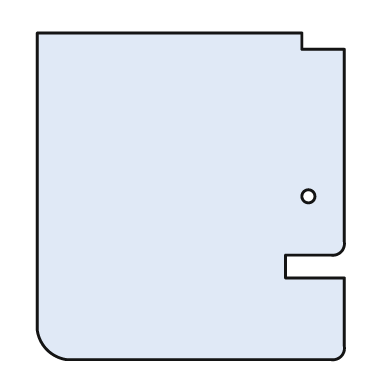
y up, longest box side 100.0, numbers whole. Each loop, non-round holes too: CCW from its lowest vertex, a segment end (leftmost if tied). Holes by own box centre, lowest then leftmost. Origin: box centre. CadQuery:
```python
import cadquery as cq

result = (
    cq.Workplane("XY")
    .moveTo(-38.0, -50.0)
    .lineTo(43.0, -50.0)
    .threePointArc((46.0, -49.0), (47.0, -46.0))
    .lineTo(47.0, -25.0)
    .lineTo(29.0, -25.0)
    .lineTo(29.0, -18.0)
    .lineTo(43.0, -18.0)
    .threePointArc((46.0, -17.0), (47.0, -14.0))
    .lineTo(47.0, 45.0)
    .lineTo(34.0, 45.0)
    .lineTo(34.0, 50.0)
    .lineTo(-47.0, 50.0)
    .lineTo(-47.0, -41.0)
    .threePointArc((-44.0, -47.0), (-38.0, -50.0))
    .close()
    .moveTo(36.0, 0.0)
    .circle(2.0)
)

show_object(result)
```